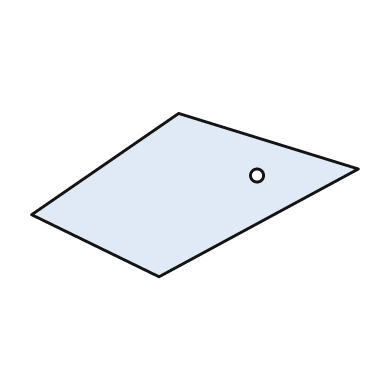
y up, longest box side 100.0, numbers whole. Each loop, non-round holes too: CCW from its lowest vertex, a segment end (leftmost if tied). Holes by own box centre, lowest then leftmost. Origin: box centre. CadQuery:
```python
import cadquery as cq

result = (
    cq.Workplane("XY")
    .moveTo(-11.0, -25.0)
    .lineTo(50.0, 8.0)
    .lineTo(-5.0, 25.0)
    .lineTo(-50.0, -6.0)
    .close()
    .moveTo(19.0, 6.0)
    .circle(2.0)
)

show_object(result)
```